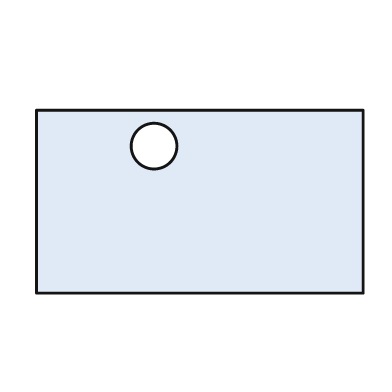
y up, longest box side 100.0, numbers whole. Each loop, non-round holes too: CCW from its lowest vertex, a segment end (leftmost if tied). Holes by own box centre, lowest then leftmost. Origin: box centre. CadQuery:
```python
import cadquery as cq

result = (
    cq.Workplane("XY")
    .moveTo(-50.0, -28.0)
    .lineTo(50.0, -28.0)
    .lineTo(50.0, 28.0)
    .lineTo(-50.0, 28.0)
    .close()
    .moveTo(-14.0, 17.0)
    .circle(7.0)
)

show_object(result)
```